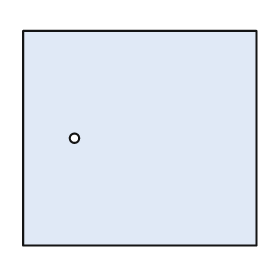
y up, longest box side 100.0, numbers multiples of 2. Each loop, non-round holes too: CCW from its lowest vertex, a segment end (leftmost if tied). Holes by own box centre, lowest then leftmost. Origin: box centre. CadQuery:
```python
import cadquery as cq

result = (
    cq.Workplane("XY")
    .moveTo(-50.0, -46.0)
    .lineTo(50.0, -46.0)
    .lineTo(50.0, 46.0)
    .lineTo(-50.0, 46.0)
    .close()
    .moveTo(-28.0, 0.0)
    .circle(2.0)
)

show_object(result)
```